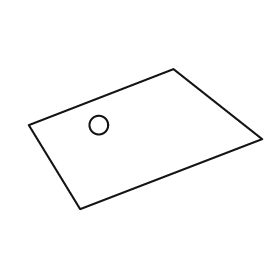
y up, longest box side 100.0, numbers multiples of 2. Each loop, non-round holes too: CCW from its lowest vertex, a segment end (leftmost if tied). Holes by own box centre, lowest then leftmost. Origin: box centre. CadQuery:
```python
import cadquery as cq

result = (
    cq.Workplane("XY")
    .moveTo(-28.0, -30.0)
    .lineTo(50.0, 0.0)
    .lineTo(12.0, 30.0)
    .lineTo(-50.0, 6.0)
    .close()
    .moveTo(-20.0, 6.0)
    .circle(4.0)
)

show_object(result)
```